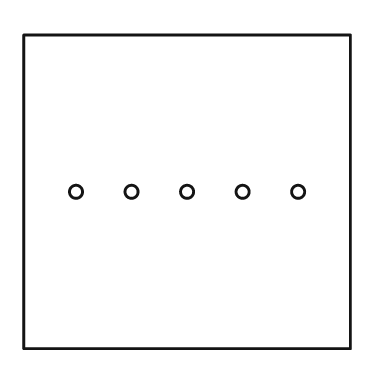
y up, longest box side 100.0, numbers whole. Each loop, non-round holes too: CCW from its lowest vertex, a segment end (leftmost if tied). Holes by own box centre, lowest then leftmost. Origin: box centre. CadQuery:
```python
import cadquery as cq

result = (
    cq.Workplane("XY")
    .moveTo(-50.0, -48.0)
    .lineTo(50.0, -48.0)
    .lineTo(50.0, 48.0)
    .lineTo(-50.0, 48.0)
    .close()
    .moveTo(-34.0, 0.0)
    .circle(2.0)
    .moveTo(-17.0, 0.0)
    .circle(2.0)
    .moveTo(0.0, 0.0)
    .circle(2.0)
    .moveTo(17.0, 0.0)
    .circle(2.0)
    .moveTo(34.0, 0.0)
    .circle(2.0)
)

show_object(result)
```